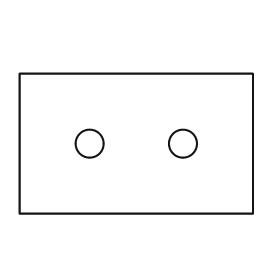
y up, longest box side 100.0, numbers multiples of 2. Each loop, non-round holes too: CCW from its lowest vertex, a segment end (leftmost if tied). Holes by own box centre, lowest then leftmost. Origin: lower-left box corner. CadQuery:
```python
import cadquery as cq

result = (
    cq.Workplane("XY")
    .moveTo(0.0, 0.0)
    .lineTo(100.0, 0.0)
    .lineTo(100.0, 60.0)
    .lineTo(0.0, 60.0)
    .close()
    .moveTo(30.0, 30.0)
    .circle(6.0)
    .moveTo(70.0, 30.0)
    .circle(6.0)
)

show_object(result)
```